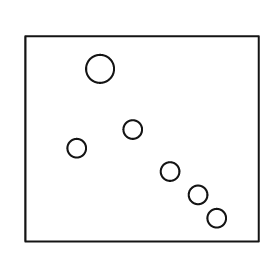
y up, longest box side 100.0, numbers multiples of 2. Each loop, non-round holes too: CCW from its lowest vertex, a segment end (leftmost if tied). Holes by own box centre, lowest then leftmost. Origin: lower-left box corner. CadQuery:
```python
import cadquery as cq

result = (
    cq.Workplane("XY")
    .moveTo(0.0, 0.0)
    .lineTo(100.0, 0.0)
    .lineTo(100.0, 88.0)
    .lineTo(0.0, 88.0)
    .close()
    .moveTo(82.0, 10.0)
    .circle(4.0)
    .moveTo(74.0, 20.0)
    .circle(4.0)
    .moveTo(62.0, 30.0)
    .circle(4.0)
    .moveTo(22.0, 40.0)
    .circle(4.0)
    .moveTo(46.0, 48.0)
    .circle(4.0)
    .moveTo(32.0, 74.0)
    .circle(6.0)
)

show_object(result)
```